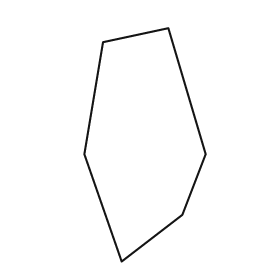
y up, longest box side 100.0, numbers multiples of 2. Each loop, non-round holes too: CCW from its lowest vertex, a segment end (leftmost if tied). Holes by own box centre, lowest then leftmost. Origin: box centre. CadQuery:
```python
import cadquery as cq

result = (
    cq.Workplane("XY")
    .moveTo(-10.0, -50.0)
    .lineTo(16.0, -30.0)
    .lineTo(26.0, -4.0)
    .lineTo(10.0, 50.0)
    .lineTo(-18.0, 44.0)
    .lineTo(-26.0, -4.0)
    .close()
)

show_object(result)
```